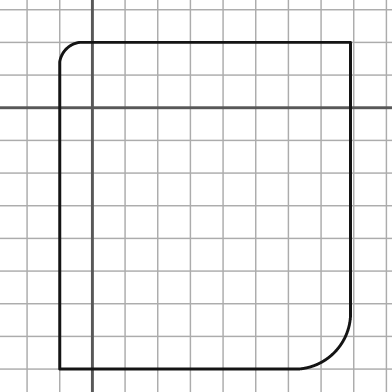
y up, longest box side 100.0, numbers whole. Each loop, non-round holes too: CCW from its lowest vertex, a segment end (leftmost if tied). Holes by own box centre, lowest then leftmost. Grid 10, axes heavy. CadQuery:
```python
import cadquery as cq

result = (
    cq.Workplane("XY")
    .moveTo(-10.0, -80.0)
    .lineTo(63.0, -80.0)
    .threePointArc((74.0, -75.0), (79.0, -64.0))
    .lineTo(79.0, 20.0)
    .lineTo(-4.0, 20.0)
    .threePointArc((-8.0, 18.0), (-10.0, 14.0))
    .close()
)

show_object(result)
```